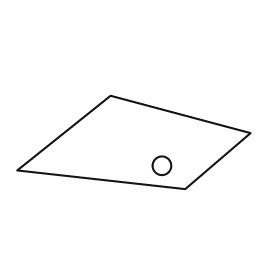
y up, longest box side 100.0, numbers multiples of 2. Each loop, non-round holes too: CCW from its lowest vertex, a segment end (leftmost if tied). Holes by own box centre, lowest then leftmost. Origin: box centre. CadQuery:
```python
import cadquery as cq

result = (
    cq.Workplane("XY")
    .moveTo(22.0, -20.0)
    .lineTo(50.0, 4.0)
    .lineTo(-10.0, 20.0)
    .lineTo(-50.0, -12.0)
    .close()
    .moveTo(12.0, -10.0)
    .circle(4.0)
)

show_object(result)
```